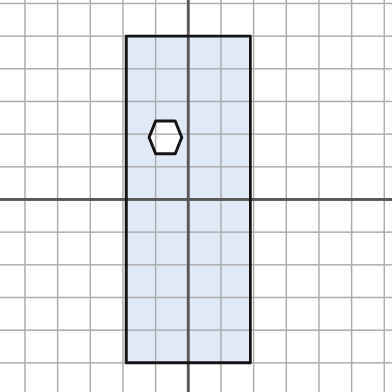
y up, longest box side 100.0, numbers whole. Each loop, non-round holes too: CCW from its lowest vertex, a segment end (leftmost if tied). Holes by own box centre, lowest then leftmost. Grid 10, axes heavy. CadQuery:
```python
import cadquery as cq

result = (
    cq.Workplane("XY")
    .moveTo(-19.0, -50.0)
    .lineTo(19.0, -50.0)
    .lineTo(19.0, 50.0)
    .lineTo(-19.0, 50.0)
    .close()
    .moveTo(-10.0, 14.0)
    .lineTo(-4.0, 14.0)
    .lineTo(-2.0, 19.0)
    .lineTo(-4.0, 24.0)
    .lineTo(-10.0, 24.0)
    .lineTo(-12.0, 19.0)
    .close()
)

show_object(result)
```